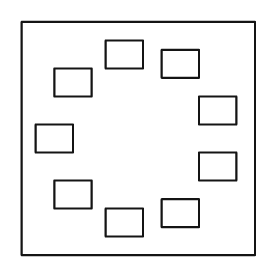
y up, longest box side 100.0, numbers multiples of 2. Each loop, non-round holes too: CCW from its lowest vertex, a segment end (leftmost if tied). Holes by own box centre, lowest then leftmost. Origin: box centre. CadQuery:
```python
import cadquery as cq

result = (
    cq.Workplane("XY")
    .moveTo(-50.0, -50.0)
    .lineTo(50.0, -50.0)
    .lineTo(50.0, 50.0)
    .lineTo(-50.0, 50.0)
    .close()
    .moveTo(-14.0, -42.0)
    .lineTo(2.0, -42.0)
    .lineTo(2.0, -30.0)
    .lineTo(-14.0, -30.0)
    .close()
    .moveTo(10.0, -38.0)
    .lineTo(26.0, -38.0)
    .lineTo(26.0, -26.0)
    .lineTo(10.0, -26.0)
    .close()
    .moveTo(-36.0, -30.0)
    .lineTo(-20.0, -30.0)
    .lineTo(-20.0, -18.0)
    .lineTo(-36.0, -18.0)
    .close()
    .moveTo(26.0, -18.0)
    .lineTo(42.0, -18.0)
    .lineTo(42.0, -6.0)
    .lineTo(26.0, -6.0)
    .close()
    .moveTo(-44.0, -6.0)
    .lineTo(-28.0, -6.0)
    .lineTo(-28.0, 6.0)
    .lineTo(-44.0, 6.0)
    .close()
    .moveTo(26.0, 6.0)
    .lineTo(42.0, 6.0)
    .lineTo(42.0, 18.0)
    .lineTo(26.0, 18.0)
    .close()
    .moveTo(-36.0, 18.0)
    .lineTo(-20.0, 18.0)
    .lineTo(-20.0, 30.0)
    .lineTo(-36.0, 30.0)
    .close()
    .moveTo(10.0, 26.0)
    .lineTo(26.0, 26.0)
    .lineTo(26.0, 38.0)
    .lineTo(10.0, 38.0)
    .close()
    .moveTo(-14.0, 30.0)
    .lineTo(2.0, 30.0)
    .lineTo(2.0, 42.0)
    .lineTo(-14.0, 42.0)
    .close()
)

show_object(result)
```